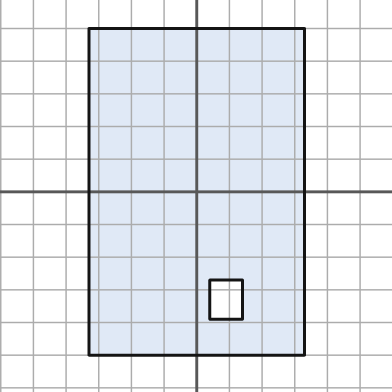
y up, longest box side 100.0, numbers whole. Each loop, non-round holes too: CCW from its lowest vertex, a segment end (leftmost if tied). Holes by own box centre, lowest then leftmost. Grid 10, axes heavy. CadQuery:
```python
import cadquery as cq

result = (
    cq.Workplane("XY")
    .moveTo(-33.0, -50.0)
    .lineTo(33.0, -50.0)
    .lineTo(33.0, 50.0)
    .lineTo(-33.0, 50.0)
    .close()
    .moveTo(4.0, -39.0)
    .lineTo(14.0, -39.0)
    .lineTo(14.0, -27.0)
    .lineTo(4.0, -27.0)
    .close()
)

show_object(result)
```